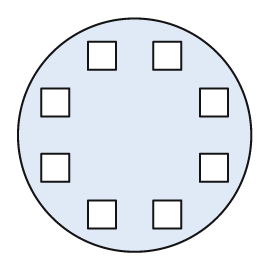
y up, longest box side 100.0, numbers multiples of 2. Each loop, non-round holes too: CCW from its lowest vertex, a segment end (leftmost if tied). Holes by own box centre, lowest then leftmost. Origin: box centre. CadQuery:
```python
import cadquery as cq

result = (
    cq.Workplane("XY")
    .moveTo(0.0, 0.0)
    .circle(50.0)
    .moveTo(-20.0, -40.0)
    .lineTo(-8.0, -40.0)
    .lineTo(-8.0, -28.0)
    .lineTo(-20.0, -28.0)
    .close()
    .moveTo(8.0, -40.0)
    .lineTo(20.0, -40.0)
    .lineTo(20.0, -28.0)
    .lineTo(8.0, -28.0)
    .close()
    .moveTo(-40.0, -20.0)
    .lineTo(-28.0, -20.0)
    .lineTo(-28.0, -8.0)
    .lineTo(-40.0, -8.0)
    .close()
    .moveTo(28.0, -20.0)
    .lineTo(40.0, -20.0)
    .lineTo(40.0, -8.0)
    .lineTo(28.0, -8.0)
    .close()
    .moveTo(-40.0, 8.0)
    .lineTo(-28.0, 8.0)
    .lineTo(-28.0, 20.0)
    .lineTo(-40.0, 20.0)
    .close()
    .moveTo(28.0, 8.0)
    .lineTo(40.0, 8.0)
    .lineTo(40.0, 20.0)
    .lineTo(28.0, 20.0)
    .close()
    .moveTo(-20.0, 28.0)
    .lineTo(-8.0, 28.0)
    .lineTo(-8.0, 40.0)
    .lineTo(-20.0, 40.0)
    .close()
    .moveTo(8.0, 28.0)
    .lineTo(20.0, 28.0)
    .lineTo(20.0, 40.0)
    .lineTo(8.0, 40.0)
    .close()
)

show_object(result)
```